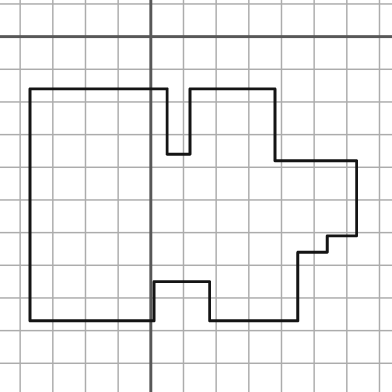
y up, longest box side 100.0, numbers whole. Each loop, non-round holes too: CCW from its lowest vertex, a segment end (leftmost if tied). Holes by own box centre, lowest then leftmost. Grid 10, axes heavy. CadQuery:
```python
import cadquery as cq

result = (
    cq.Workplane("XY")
    .moveTo(-37.0, -87.0)
    .lineTo(1.0, -87.0)
    .lineTo(1.0, -75.0)
    .lineTo(18.0, -75.0)
    .lineTo(18.0, -87.0)
    .lineTo(45.0, -87.0)
    .lineTo(45.0, -66.0)
    .lineTo(54.0, -66.0)
    .lineTo(54.0, -61.0)
    .lineTo(63.0, -61.0)
    .lineTo(63.0, -38.0)
    .lineTo(38.0, -38.0)
    .lineTo(38.0, -16.0)
    .lineTo(12.0, -16.0)
    .lineTo(12.0, -36.0)
    .lineTo(5.0, -36.0)
    .lineTo(5.0, -16.0)
    .lineTo(-37.0, -16.0)
    .close()
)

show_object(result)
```